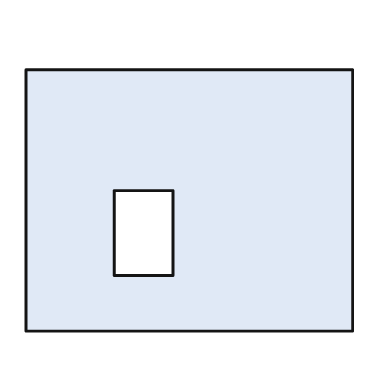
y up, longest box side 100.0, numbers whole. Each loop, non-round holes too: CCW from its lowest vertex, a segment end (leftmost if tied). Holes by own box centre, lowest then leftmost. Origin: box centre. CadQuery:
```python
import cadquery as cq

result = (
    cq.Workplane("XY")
    .moveTo(-50.0, -40.0)
    .lineTo(50.0, -40.0)
    .lineTo(50.0, 40.0)
    .lineTo(-50.0, 40.0)
    .close()
    .moveTo(-23.0, -23.0)
    .lineTo(-5.0, -23.0)
    .lineTo(-5.0, 3.0)
    .lineTo(-23.0, 3.0)
    .close()
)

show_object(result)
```